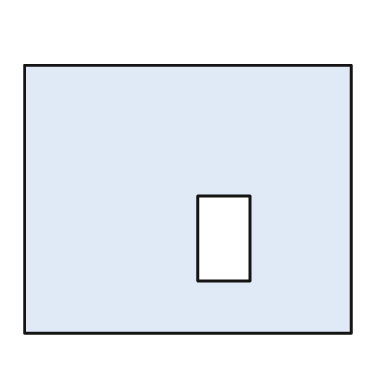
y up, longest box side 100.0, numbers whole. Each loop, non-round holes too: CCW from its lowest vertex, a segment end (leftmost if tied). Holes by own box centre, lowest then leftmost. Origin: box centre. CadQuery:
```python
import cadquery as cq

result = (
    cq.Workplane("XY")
    .moveTo(-50.0, -41.0)
    .lineTo(50.0, -41.0)
    .lineTo(50.0, 41.0)
    .lineTo(-50.0, 41.0)
    .close()
    .moveTo(3.0, -25.0)
    .lineTo(19.0, -25.0)
    .lineTo(19.0, 1.0)
    .lineTo(3.0, 1.0)
    .close()
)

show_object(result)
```